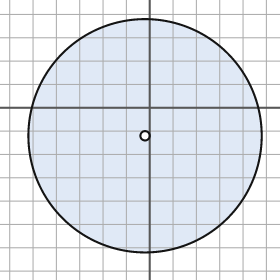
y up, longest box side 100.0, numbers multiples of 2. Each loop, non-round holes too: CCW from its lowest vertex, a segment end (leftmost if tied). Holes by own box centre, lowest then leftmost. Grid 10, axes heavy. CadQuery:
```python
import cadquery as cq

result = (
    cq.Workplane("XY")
    .moveTo(-2.0, -12.0)
    .circle(50.0)
    .moveTo(-2.0, -12.0)
    .circle(2.0)
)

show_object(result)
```